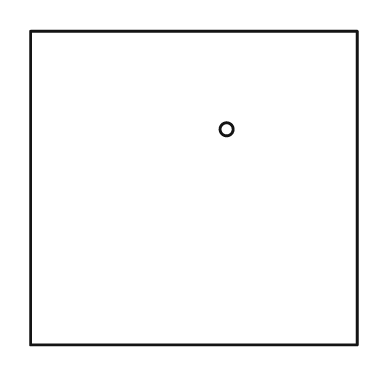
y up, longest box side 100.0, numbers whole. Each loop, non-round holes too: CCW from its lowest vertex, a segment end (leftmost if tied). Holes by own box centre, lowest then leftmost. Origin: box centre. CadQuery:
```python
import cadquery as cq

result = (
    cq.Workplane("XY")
    .moveTo(-50.0, -48.0)
    .lineTo(50.0, -48.0)
    .lineTo(50.0, 48.0)
    .lineTo(-50.0, 48.0)
    .close()
    .moveTo(10.0, 18.0)
    .circle(2.0)
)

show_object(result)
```